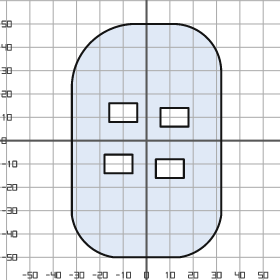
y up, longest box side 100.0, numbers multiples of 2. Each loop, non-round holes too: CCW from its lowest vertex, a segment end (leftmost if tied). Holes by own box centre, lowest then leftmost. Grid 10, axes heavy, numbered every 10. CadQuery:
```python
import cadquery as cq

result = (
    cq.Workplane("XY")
    .moveTo(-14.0, -50.0)
    .lineTo(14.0, -50.0)
    .threePointArc((26.0, -44.0), (32.0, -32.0))
    .lineTo(32.0, 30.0)
    .threePointArc((26.0, 44.0), (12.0, 50.0))
    .lineTo(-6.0, 50.0)
    .threePointArc((-24.0, 42.0), (-32.0, 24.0))
    .lineTo(-32.0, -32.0)
    .threePointArc((-26.0, -44.0), (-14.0, -50.0))
    .close()
    .moveTo(4.0, -16.0)
    .lineTo(16.0, -16.0)
    .lineTo(16.0, -8.0)
    .lineTo(4.0, -8.0)
    .close()
    .moveTo(-18.0, -14.0)
    .lineTo(-6.0, -14.0)
    .lineTo(-6.0, -6.0)
    .lineTo(-18.0, -6.0)
    .close()
    .moveTo(6.0, 6.0)
    .lineTo(18.0, 6.0)
    .lineTo(18.0, 14.0)
    .lineTo(6.0, 14.0)
    .close()
    .moveTo(-16.0, 8.0)
    .lineTo(-4.0, 8.0)
    .lineTo(-4.0, 16.0)
    .lineTo(-16.0, 16.0)
    .close()
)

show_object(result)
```